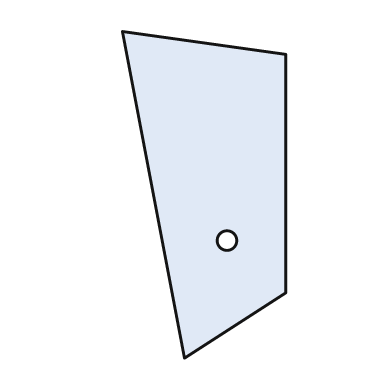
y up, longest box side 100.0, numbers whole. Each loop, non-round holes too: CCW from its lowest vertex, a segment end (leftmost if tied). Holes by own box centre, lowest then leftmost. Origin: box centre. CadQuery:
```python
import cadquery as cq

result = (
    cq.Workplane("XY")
    .moveTo(-6.0, -50.0)
    .lineTo(25.0, -30.0)
    .lineTo(25.0, 43.0)
    .lineTo(-25.0, 50.0)
    .close()
    .moveTo(7.0, -14.0)
    .circle(3.0)
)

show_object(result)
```